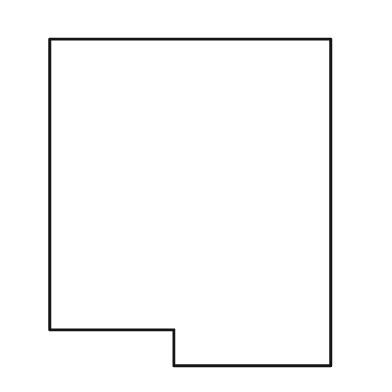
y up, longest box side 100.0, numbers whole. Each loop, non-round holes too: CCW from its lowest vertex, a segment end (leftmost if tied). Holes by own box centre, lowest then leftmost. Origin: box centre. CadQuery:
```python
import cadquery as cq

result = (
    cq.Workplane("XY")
    .moveTo(-5.0, -50.0)
    .lineTo(43.0, -50.0)
    .lineTo(43.0, 50.0)
    .lineTo(-43.0, 50.0)
    .lineTo(-43.0, -39.0)
    .lineTo(-5.0, -39.0)
    .close()
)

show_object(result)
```